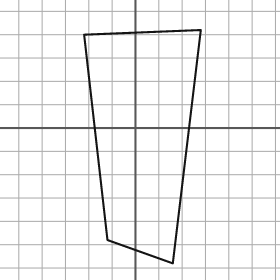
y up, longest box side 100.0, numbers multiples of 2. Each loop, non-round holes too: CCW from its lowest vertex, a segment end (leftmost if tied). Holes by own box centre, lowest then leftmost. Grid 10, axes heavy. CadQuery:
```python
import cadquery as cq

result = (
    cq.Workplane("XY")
    .moveTo(16.0, -58.0)
    .lineTo(28.0, 42.0)
    .lineTo(-22.0, 40.0)
    .lineTo(-12.0, -48.0)
    .close()
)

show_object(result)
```